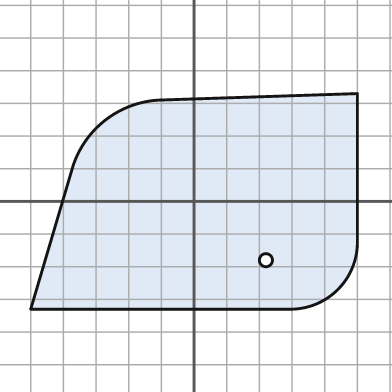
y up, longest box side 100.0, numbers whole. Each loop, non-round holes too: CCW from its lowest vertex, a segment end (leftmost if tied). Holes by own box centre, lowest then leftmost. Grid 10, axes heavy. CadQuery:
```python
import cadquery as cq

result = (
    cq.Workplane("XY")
    .moveTo(-50.0, -33.0)
    .lineTo(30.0, -33.0)
    .threePointArc((44.0, -27.0), (50.0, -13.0))
    .lineTo(50.0, 33.0)
    .lineTo(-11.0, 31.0)
    .threePointArc((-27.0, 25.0), (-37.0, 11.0))
    .close()
    .moveTo(22.0, -18.0)
    .circle(2.0)
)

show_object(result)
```